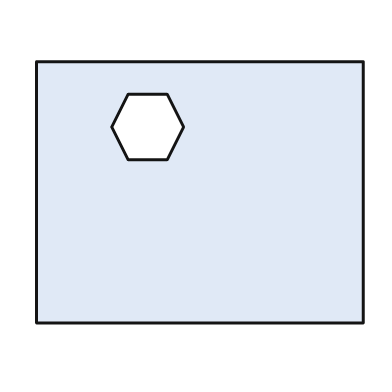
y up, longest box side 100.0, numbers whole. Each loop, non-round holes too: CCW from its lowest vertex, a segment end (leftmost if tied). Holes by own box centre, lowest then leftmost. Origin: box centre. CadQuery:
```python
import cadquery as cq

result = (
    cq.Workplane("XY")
    .moveTo(-50.0, -40.0)
    .lineTo(50.0, -40.0)
    .lineTo(50.0, 40.0)
    .lineTo(-50.0, 40.0)
    .close()
    .moveTo(-22.0, 10.0)
    .lineTo(-10.0, 10.0)
    .lineTo(-5.0, 20.0)
    .lineTo(-10.0, 30.0)
    .lineTo(-22.0, 30.0)
    .lineTo(-27.0, 20.0)
    .close()
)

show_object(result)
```